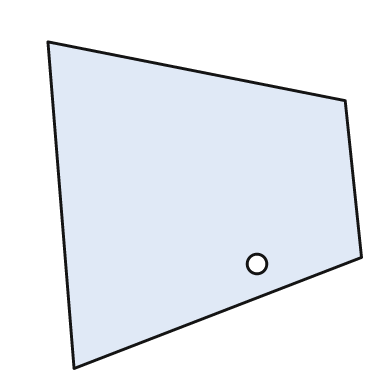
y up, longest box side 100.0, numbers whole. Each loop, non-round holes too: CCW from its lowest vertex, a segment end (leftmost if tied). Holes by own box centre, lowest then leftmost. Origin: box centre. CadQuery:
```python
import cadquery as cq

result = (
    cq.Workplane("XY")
    .moveTo(-40.0, -50.0)
    .lineTo(48.0, -16.0)
    .lineTo(43.0, 32.0)
    .lineTo(-48.0, 50.0)
    .close()
    .moveTo(16.0, -18.0)
    .circle(3.0)
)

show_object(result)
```